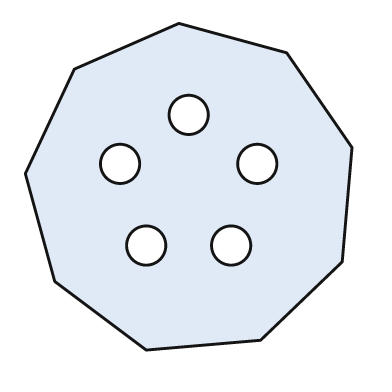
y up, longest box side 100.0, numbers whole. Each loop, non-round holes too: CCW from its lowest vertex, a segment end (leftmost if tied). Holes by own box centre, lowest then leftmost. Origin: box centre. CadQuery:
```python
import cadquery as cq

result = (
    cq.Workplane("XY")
    .moveTo(-13.0, -50.0)
    .lineTo(22.0, -47.0)
    .lineTo(47.0, -23.0)
    .lineTo(50.0, 12.0)
    .lineTo(30.0, 41.0)
    .lineTo(-3.0, 50.0)
    .lineTo(-35.0, 36.0)
    .lineTo(-50.0, 4.0)
    .lineTo(-41.0, -29.0)
    .close()
    .moveTo(-13.0, -18.0)
    .circle(6.0)
    .moveTo(13.0, -18.0)
    .circle(6.0)
    .moveTo(-21.0, 7.0)
    .circle(6.0)
    .moveTo(21.0, 7.0)
    .circle(6.0)
    .moveTo(0.0, 22.0)
    .circle(6.0)
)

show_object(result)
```